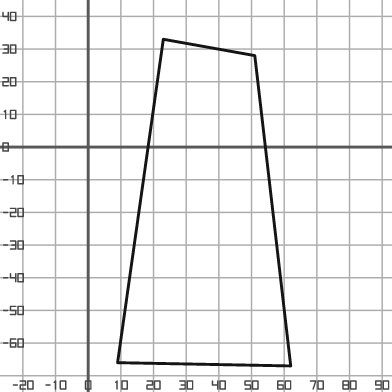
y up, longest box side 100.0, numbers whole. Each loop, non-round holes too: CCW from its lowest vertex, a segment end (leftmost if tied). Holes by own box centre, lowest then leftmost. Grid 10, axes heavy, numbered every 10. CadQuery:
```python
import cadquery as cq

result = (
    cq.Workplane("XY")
    .moveTo(62.0, -67.0)
    .lineTo(51.0, 28.0)
    .lineTo(23.0, 33.0)
    .lineTo(9.0, -66.0)
    .close()
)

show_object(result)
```